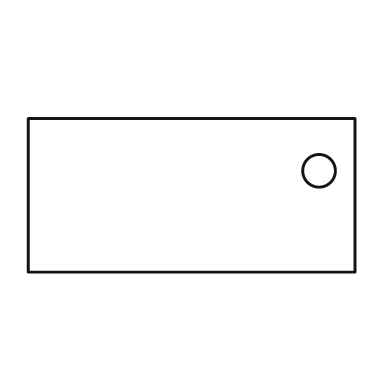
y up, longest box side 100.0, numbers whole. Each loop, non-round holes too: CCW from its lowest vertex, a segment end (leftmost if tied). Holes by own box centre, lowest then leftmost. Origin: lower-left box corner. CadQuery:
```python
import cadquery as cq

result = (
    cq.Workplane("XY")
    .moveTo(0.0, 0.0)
    .lineTo(100.0, 0.0)
    .lineTo(100.0, 47.0)
    .lineTo(0.0, 47.0)
    .close()
    .moveTo(89.0, 31.0)
    .circle(5.0)
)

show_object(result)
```